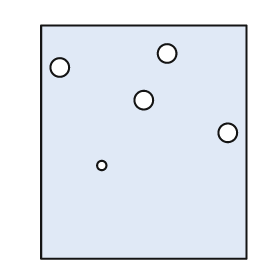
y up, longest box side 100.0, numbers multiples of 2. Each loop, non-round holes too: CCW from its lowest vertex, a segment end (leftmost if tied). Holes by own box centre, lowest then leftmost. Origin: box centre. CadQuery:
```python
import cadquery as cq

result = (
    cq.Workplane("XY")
    .moveTo(-44.0, -50.0)
    .lineTo(44.0, -50.0)
    .lineTo(44.0, 50.0)
    .lineTo(-44.0, 50.0)
    .close()
    .moveTo(-18.0, -10.0)
    .circle(2.0)
    .moveTo(36.0, 4.0)
    .circle(4.0)
    .moveTo(0.0, 18.0)
    .circle(4.0)
    .moveTo(-36.0, 32.0)
    .circle(4.0)
    .moveTo(10.0, 38.0)
    .circle(4.0)
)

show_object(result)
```